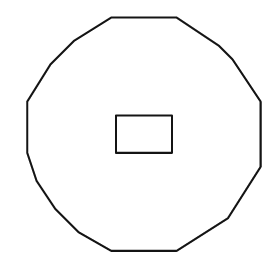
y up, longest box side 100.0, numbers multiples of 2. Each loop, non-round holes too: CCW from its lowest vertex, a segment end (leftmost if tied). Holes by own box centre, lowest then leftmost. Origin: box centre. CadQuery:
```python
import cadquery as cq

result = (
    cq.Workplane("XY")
    .moveTo(-14.0, -50.0)
    .lineTo(14.0, -50.0)
    .lineTo(36.0, -36.0)
    .lineTo(50.0, -14.0)
    .lineTo(50.0, 14.0)
    .lineTo(38.0, 32.0)
    .lineTo(32.0, 38.0)
    .lineTo(14.0, 50.0)
    .lineTo(-14.0, 50.0)
    .lineTo(-30.0, 40.0)
    .lineTo(-40.0, 30.0)
    .lineTo(-50.0, 14.0)
    .lineTo(-50.0, -8.0)
    .lineTo(-46.0, -20.0)
    .lineTo(-38.0, -32.0)
    .lineTo(-28.0, -42.0)
    .close()
    .moveTo(-12.0, -8.0)
    .lineTo(12.0, -8.0)
    .lineTo(12.0, 8.0)
    .lineTo(-12.0, 8.0)
    .close()
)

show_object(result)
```